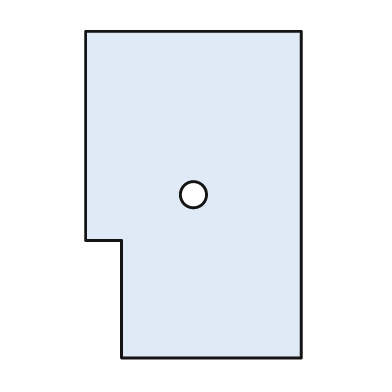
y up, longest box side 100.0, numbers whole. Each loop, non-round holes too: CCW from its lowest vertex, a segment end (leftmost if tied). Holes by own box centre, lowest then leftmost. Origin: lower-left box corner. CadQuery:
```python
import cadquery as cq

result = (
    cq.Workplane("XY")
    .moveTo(11.0, 0.0)
    .lineTo(66.0, 0.0)
    .lineTo(66.0, 100.0)
    .lineTo(0.0, 100.0)
    .lineTo(0.0, 36.0)
    .lineTo(11.0, 36.0)
    .close()
    .moveTo(33.0, 50.0)
    .circle(4.0)
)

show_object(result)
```